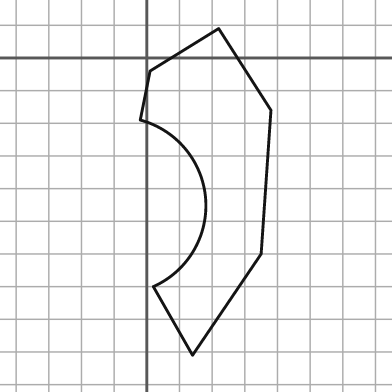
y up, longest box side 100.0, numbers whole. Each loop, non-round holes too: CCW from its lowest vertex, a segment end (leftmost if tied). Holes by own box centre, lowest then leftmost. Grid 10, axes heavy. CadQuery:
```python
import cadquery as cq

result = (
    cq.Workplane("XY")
    .moveTo(14.0, -91.0)
    .lineTo(35.0, -60.0)
    .lineTo(38.0, -16.0)
    .lineTo(22.0, 9.0)
    .lineTo(1.0, -4.0)
    .lineTo(-2.0, -19.0)
    .threePointArc((18.0, -43.0), (2.0, -70.0))
    .close()
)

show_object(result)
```